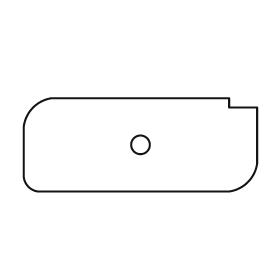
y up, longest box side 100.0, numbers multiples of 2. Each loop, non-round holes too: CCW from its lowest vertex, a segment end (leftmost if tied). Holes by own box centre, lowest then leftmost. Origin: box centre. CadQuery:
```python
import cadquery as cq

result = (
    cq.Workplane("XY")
    .moveTo(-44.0, -20.0)
    .lineTo(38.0, -20.0)
    .threePointArc((46.0, -16.0), (50.0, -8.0))
    .lineTo(50.0, 16.0)
    .lineTo(38.0, 16.0)
    .lineTo(38.0, 20.0)
    .lineTo(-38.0, 20.0)
    .threePointArc((-46.0, 16.0), (-50.0, 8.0))
    .lineTo(-50.0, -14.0)
    .threePointArc((-48.0, -18.0), (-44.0, -20.0))
    .close()
    .moveTo(0.0, 0.0)
    .circle(4.0)
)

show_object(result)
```